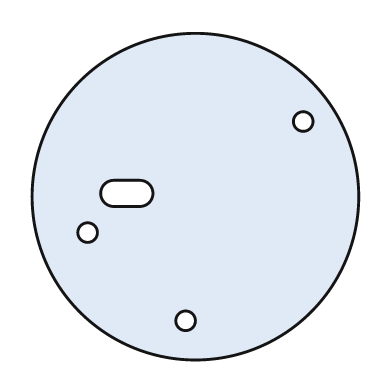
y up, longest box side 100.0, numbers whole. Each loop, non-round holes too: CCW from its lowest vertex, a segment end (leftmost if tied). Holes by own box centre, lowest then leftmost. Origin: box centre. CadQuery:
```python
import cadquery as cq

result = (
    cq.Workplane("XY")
    .moveTo(0.0, 0.0)
    .circle(50.0)
    .moveTo(-3.0, -38.0)
    .circle(3.0)
    .moveTo(-33.0, -11.0)
    .circle(3.0)
    .moveTo(-25.0, -3.0)
    .lineTo(-17.0, -3.0)
    .threePointArc((-13.0, 1.0), (-17.0, 5.0))
    .lineTo(-25.0, 5.0)
    .threePointArc((-29.0, 1.0), (-25.0, -3.0))
    .close()
    .moveTo(33.0, 23.0)
    .circle(3.0)
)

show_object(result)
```